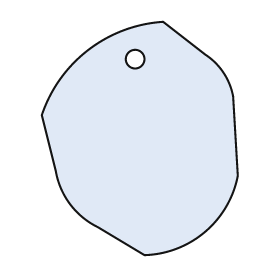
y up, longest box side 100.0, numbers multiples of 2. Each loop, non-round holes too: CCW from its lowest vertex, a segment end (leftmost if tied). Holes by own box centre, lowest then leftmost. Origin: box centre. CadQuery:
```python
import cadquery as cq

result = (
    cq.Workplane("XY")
    .moveTo(2.0, -50.0)
    .threePointArc((28.0, -40.0), (42.0, -16.0))
    .lineTo(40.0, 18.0)
    .threePointArc((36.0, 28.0), (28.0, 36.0))
    .lineTo(10.0, 50.0)
    .threePointArc((-22.0, 38.0), (-42.0, 10.0))
    .lineTo(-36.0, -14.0)
    .threePointArc((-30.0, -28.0), (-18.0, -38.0))
    .close()
    .moveTo(-2.0, 34.0)
    .circle(4.0)
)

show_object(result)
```